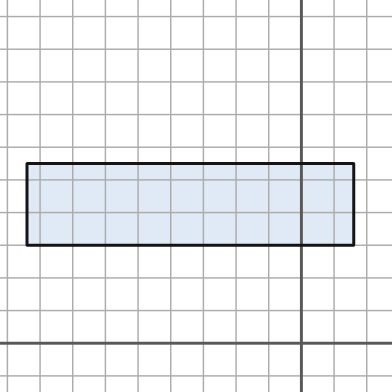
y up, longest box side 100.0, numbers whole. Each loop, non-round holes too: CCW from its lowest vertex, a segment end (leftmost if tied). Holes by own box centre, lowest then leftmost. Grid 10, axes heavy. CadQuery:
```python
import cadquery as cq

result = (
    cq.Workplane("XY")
    .moveTo(-84.0, 30.0)
    .lineTo(16.0, 30.0)
    .lineTo(16.0, 55.0)
    .lineTo(-84.0, 55.0)
    .close()
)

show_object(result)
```